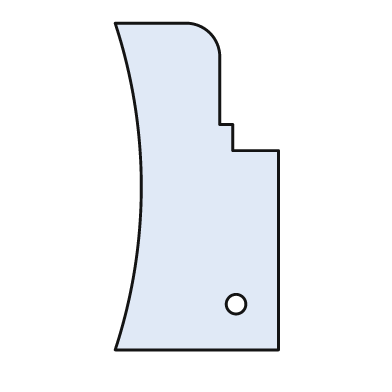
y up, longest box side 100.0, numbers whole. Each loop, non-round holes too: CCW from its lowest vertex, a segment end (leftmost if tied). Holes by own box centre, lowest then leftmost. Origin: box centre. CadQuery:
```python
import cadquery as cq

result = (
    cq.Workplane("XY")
    .moveTo(-25.0, -50.0)
    .lineTo(25.0, -50.0)
    .lineTo(25.0, 11.0)
    .lineTo(11.0, 11.0)
    .lineTo(11.0, 19.0)
    .lineTo(7.0, 19.0)
    .lineTo(7.0, 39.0)
    .threePointArc((4.0, 47.0), (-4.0, 50.0))
    .lineTo(-25.0, 50.0)
    .threePointArc((-17.0, 0.0), (-25.0, -50.0))
    .close()
    .moveTo(12.0, -36.0)
    .circle(3.0)
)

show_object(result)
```